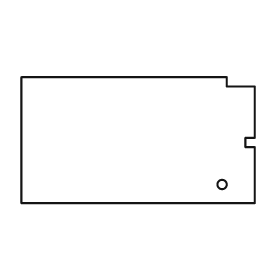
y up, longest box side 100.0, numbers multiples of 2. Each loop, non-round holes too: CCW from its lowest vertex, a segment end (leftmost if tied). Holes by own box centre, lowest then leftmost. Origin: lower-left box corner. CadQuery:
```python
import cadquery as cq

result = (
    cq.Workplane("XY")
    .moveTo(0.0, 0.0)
    .lineTo(100.0, 0.0)
    .lineTo(100.0, 24.0)
    .lineTo(96.0, 24.0)
    .lineTo(96.0, 28.0)
    .lineTo(100.0, 28.0)
    .lineTo(100.0, 50.0)
    .lineTo(88.0, 50.0)
    .lineTo(88.0, 54.0)
    .lineTo(0.0, 54.0)
    .close()
    .moveTo(86.0, 8.0)
    .circle(2.0)
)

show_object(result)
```